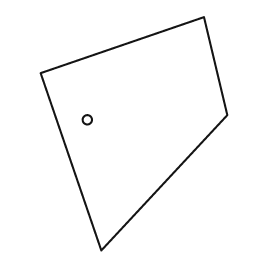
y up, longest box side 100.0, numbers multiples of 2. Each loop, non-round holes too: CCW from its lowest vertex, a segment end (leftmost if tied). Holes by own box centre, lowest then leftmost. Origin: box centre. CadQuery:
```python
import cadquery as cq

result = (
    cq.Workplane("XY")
    .moveTo(-14.0, -50.0)
    .lineTo(40.0, 8.0)
    .lineTo(30.0, 50.0)
    .lineTo(-40.0, 26.0)
    .close()
    .moveTo(-20.0, 6.0)
    .circle(2.0)
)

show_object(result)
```